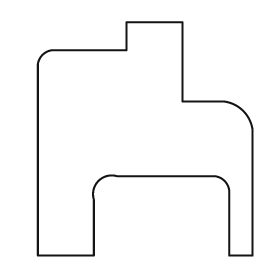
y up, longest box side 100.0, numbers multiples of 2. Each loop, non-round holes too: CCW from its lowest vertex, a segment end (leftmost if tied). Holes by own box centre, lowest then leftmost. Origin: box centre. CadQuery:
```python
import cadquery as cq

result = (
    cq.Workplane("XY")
    .moveTo(-46.0, -50.0)
    .lineTo(-22.0, -50.0)
    .lineTo(-22.0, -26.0)
    .threePointArc((-20.0, -18.0), (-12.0, -16.0))
    .lineTo(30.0, -16.0)
    .threePointArc((34.0, -18.0), (36.0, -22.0))
    .lineTo(36.0, -50.0)
    .lineTo(46.0, -50.0)
    .lineTo(46.0, 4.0)
    .threePointArc((42.0, 12.0), (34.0, 16.0))
    .lineTo(16.0, 16.0)
    .lineTo(16.0, 50.0)
    .lineTo(-8.0, 50.0)
    .lineTo(-8.0, 38.0)
    .lineTo(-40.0, 38.0)
    .threePointArc((-44.0, 36.0), (-46.0, 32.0))
    .close()
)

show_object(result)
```